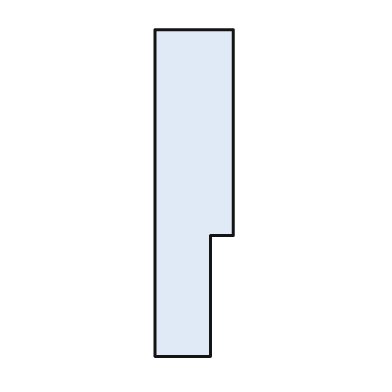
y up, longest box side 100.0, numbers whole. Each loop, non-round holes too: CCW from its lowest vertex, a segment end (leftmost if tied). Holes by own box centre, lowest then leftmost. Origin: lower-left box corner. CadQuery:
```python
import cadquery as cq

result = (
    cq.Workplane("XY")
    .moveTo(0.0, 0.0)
    .lineTo(17.0, 0.0)
    .lineTo(17.0, 37.0)
    .lineTo(24.0, 37.0)
    .lineTo(24.0, 100.0)
    .lineTo(0.0, 100.0)
    .close()
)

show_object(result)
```